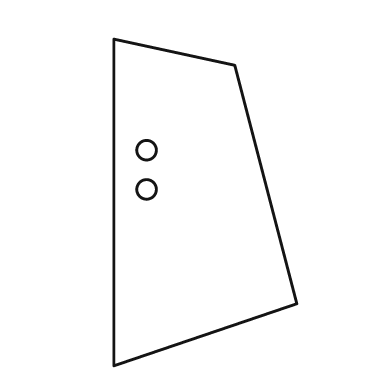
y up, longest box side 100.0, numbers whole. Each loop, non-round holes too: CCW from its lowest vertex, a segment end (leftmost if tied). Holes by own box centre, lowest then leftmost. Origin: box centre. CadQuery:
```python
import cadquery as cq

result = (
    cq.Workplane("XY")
    .moveTo(-28.0, -50.0)
    .lineTo(28.0, -31.0)
    .lineTo(9.0, 42.0)
    .lineTo(-28.0, 50.0)
    .close()
    .moveTo(-18.0, 4.0)
    .circle(3.0)
    .moveTo(-18.0, 16.0)
    .circle(3.0)
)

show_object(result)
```